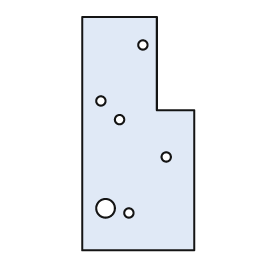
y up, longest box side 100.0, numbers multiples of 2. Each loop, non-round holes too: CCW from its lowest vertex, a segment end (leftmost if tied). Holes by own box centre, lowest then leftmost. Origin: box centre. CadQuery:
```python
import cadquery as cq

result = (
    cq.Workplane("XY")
    .moveTo(-24.0, -50.0)
    .lineTo(24.0, -50.0)
    .lineTo(24.0, 10.0)
    .lineTo(8.0, 10.0)
    .lineTo(8.0, 50.0)
    .lineTo(-24.0, 50.0)
    .close()
    .moveTo(-4.0, -34.0)
    .circle(2.0)
    .moveTo(-14.0, -32.0)
    .circle(4.0)
    .moveTo(12.0, -10.0)
    .circle(2.0)
    .moveTo(-8.0, 6.0)
    .circle(2.0)
    .moveTo(-16.0, 14.0)
    .circle(2.0)
    .moveTo(2.0, 38.0)
    .circle(2.0)
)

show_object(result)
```